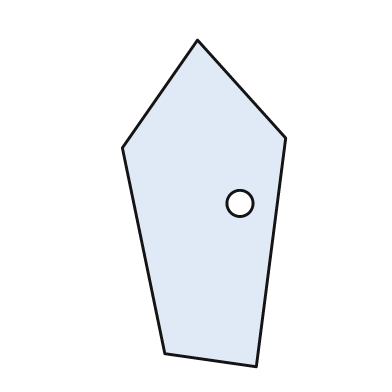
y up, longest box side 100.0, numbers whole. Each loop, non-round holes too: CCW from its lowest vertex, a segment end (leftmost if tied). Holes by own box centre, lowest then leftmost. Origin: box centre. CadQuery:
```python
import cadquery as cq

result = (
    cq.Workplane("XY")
    .moveTo(16.0, -50.0)
    .lineTo(25.0, 20.0)
    .lineTo(-2.0, 50.0)
    .lineTo(-25.0, 17.0)
    .lineTo(-12.0, -46.0)
    .close()
    .moveTo(11.0, 0.0)
    .circle(4.0)
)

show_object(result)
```